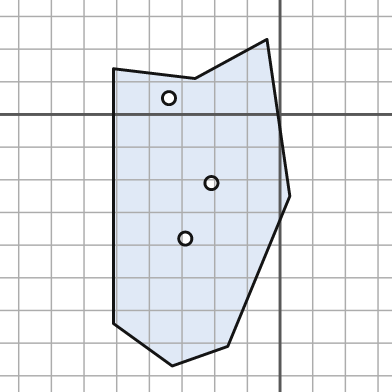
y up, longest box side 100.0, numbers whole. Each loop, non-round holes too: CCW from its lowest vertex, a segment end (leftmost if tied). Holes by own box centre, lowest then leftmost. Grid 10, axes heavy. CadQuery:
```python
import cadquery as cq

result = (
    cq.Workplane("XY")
    .moveTo(-33.0, -77.0)
    .lineTo(-16.0, -71.0)
    .lineTo(3.0, -25.0)
    .lineTo(-4.0, 23.0)
    .lineTo(-26.0, 11.0)
    .lineTo(-51.0, 14.0)
    .lineTo(-51.0, -64.0)
    .close()
    .moveTo(-29.0, -38.0)
    .circle(2.0)
    .moveTo(-21.0, -21.0)
    .circle(2.0)
    .moveTo(-34.0, 5.0)
    .circle(2.0)
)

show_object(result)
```